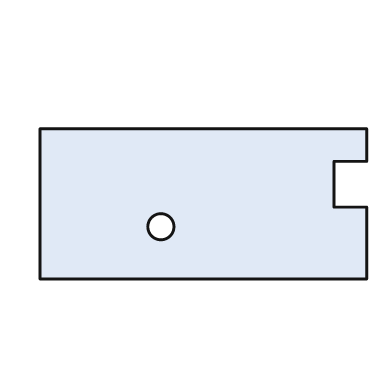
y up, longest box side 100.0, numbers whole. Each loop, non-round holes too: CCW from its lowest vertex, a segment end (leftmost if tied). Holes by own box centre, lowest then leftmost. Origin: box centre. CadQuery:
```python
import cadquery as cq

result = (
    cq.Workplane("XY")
    .moveTo(-50.0, -23.0)
    .lineTo(50.0, -23.0)
    .lineTo(50.0, -1.0)
    .lineTo(40.0, -1.0)
    .lineTo(40.0, 13.0)
    .lineTo(50.0, 13.0)
    .lineTo(50.0, 23.0)
    .lineTo(-50.0, 23.0)
    .close()
    .moveTo(-13.0, -7.0)
    .circle(4.0)
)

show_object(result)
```